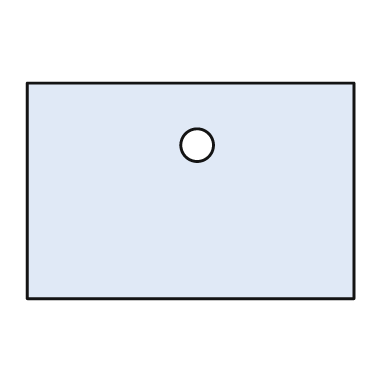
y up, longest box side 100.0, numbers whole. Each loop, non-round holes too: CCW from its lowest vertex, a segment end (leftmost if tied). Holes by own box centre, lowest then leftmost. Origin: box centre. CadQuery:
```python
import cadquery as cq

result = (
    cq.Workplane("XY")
    .moveTo(-50.0, -33.0)
    .lineTo(50.0, -33.0)
    .lineTo(50.0, 33.0)
    .lineTo(-50.0, 33.0)
    .close()
    .moveTo(2.0, 14.0)
    .circle(5.0)
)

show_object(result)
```